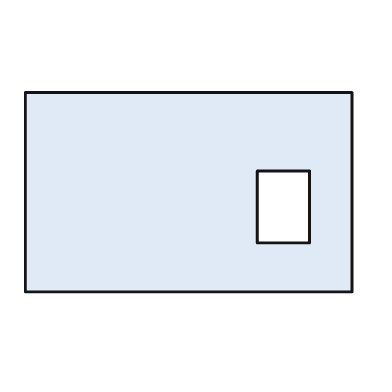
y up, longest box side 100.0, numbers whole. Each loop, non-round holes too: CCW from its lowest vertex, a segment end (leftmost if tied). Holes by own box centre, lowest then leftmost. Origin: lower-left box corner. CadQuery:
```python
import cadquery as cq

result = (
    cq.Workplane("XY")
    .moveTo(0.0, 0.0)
    .lineTo(100.0, 0.0)
    .lineTo(100.0, 61.0)
    .lineTo(0.0, 61.0)
    .close()
    .moveTo(71.0, 15.0)
    .lineTo(87.0, 15.0)
    .lineTo(87.0, 37.0)
    .lineTo(71.0, 37.0)
    .close()
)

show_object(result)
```